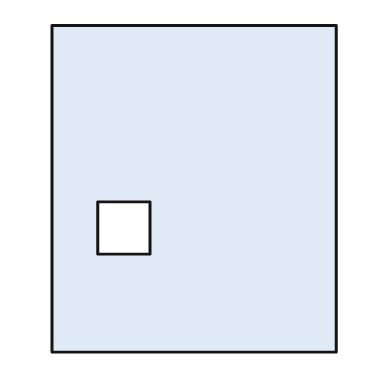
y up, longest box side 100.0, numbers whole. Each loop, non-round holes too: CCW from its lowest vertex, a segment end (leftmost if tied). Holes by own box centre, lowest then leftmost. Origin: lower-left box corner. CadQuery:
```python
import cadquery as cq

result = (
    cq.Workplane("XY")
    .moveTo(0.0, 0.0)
    .lineTo(87.0, 0.0)
    .lineTo(87.0, 100.0)
    .lineTo(0.0, 100.0)
    .close()
    .moveTo(14.0, 30.0)
    .lineTo(30.0, 30.0)
    .lineTo(30.0, 46.0)
    .lineTo(14.0, 46.0)
    .close()
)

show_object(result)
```